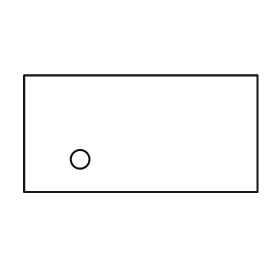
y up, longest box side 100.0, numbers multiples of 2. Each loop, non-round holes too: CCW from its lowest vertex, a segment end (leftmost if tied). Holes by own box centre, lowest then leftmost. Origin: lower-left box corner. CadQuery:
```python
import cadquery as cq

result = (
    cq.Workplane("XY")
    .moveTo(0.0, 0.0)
    .lineTo(100.0, 0.0)
    .lineTo(100.0, 50.0)
    .lineTo(0.0, 50.0)
    .close()
    .moveTo(24.0, 14.0)
    .circle(4.0)
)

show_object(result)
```